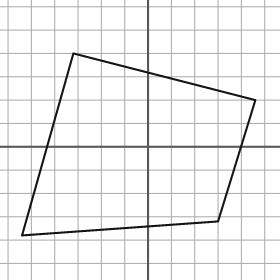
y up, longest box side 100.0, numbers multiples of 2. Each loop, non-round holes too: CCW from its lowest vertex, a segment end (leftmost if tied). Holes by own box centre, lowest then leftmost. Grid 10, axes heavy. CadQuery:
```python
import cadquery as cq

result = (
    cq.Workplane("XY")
    .moveTo(-54.0, -38.0)
    .lineTo(30.0, -32.0)
    .lineTo(46.0, 20.0)
    .lineTo(-32.0, 40.0)
    .close()
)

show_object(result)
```